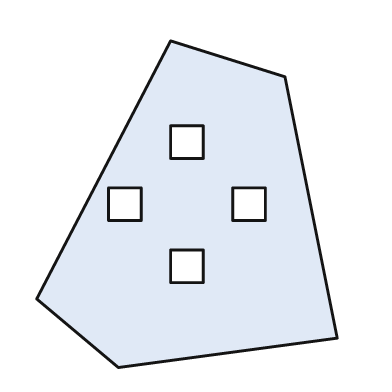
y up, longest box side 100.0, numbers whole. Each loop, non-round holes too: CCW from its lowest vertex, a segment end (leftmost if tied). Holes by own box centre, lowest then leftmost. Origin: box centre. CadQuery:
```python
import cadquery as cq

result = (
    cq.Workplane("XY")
    .moveTo(-21.0, -50.0)
    .lineTo(46.0, -41.0)
    .lineTo(30.0, 39.0)
    .lineTo(-5.0, 50.0)
    .lineTo(-46.0, -29.0)
    .close()
    .moveTo(-5.0, -24.0)
    .lineTo(5.0, -24.0)
    .lineTo(5.0, -14.0)
    .lineTo(-5.0, -14.0)
    .close()
    .moveTo(-24.0, -5.0)
    .lineTo(-14.0, -5.0)
    .lineTo(-14.0, 5.0)
    .lineTo(-24.0, 5.0)
    .close()
    .moveTo(14.0, -5.0)
    .lineTo(24.0, -5.0)
    .lineTo(24.0, 5.0)
    .lineTo(14.0, 5.0)
    .close()
    .moveTo(-5.0, 14.0)
    .lineTo(5.0, 14.0)
    .lineTo(5.0, 24.0)
    .lineTo(-5.0, 24.0)
    .close()
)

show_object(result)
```